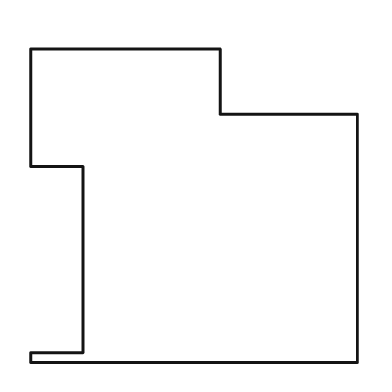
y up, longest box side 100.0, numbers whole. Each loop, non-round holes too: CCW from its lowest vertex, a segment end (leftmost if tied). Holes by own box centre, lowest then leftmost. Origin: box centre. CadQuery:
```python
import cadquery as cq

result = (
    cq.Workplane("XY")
    .moveTo(-50.0, -48.0)
    .lineTo(50.0, -48.0)
    .lineTo(50.0, 28.0)
    .lineTo(8.0, 28.0)
    .lineTo(8.0, 48.0)
    .lineTo(-50.0, 48.0)
    .lineTo(-50.0, 12.0)
    .lineTo(-34.0, 12.0)
    .lineTo(-34.0, -45.0)
    .lineTo(-50.0, -45.0)
    .close()
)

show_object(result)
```